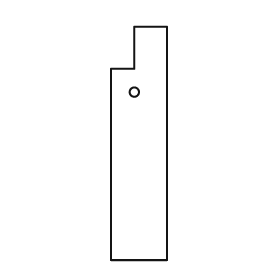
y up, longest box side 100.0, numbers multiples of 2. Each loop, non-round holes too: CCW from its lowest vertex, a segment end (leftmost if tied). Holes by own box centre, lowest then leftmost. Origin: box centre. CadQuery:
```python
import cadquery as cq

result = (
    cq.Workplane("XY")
    .moveTo(-12.0, -50.0)
    .lineTo(12.0, -50.0)
    .lineTo(12.0, 50.0)
    .lineTo(-2.0, 50.0)
    .lineTo(-2.0, 32.0)
    .lineTo(-12.0, 32.0)
    .close()
    .moveTo(-2.0, 22.0)
    .circle(2.0)
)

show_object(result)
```